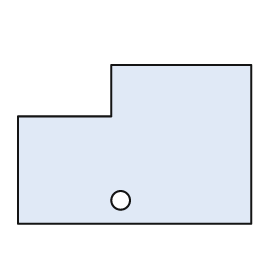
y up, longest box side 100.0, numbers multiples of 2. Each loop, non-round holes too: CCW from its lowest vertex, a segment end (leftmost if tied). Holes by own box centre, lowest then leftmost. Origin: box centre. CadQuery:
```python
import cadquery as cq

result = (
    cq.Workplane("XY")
    .moveTo(-50.0, -34.0)
    .lineTo(50.0, -34.0)
    .lineTo(50.0, 34.0)
    .lineTo(-10.0, 34.0)
    .lineTo(-10.0, 12.0)
    .lineTo(-50.0, 12.0)
    .close()
    .moveTo(-6.0, -24.0)
    .circle(4.0)
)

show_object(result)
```